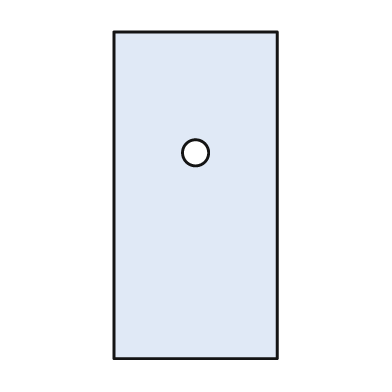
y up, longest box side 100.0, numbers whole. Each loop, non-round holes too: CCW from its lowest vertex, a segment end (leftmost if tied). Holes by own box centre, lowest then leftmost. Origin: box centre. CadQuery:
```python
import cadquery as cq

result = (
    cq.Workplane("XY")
    .moveTo(-25.0, -50.0)
    .lineTo(25.0, -50.0)
    .lineTo(25.0, 50.0)
    .lineTo(-25.0, 50.0)
    .close()
    .moveTo(0.0, 13.0)
    .circle(4.0)
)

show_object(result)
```